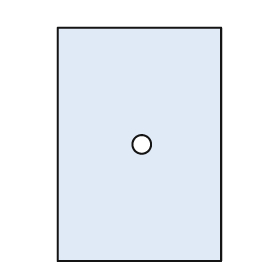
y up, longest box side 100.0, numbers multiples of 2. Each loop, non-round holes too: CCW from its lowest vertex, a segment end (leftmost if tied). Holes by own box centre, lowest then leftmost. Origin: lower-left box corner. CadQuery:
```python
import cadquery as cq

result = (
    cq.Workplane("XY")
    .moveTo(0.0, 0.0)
    .lineTo(70.0, 0.0)
    .lineTo(70.0, 100.0)
    .lineTo(0.0, 100.0)
    .close()
    .moveTo(36.0, 50.0)
    .circle(4.0)
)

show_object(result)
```